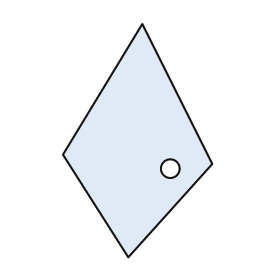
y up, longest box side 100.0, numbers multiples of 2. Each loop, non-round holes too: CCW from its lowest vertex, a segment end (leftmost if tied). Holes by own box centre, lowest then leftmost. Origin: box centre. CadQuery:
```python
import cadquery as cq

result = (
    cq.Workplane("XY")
    .moveTo(-4.0, -50.0)
    .lineTo(32.0, -10.0)
    .lineTo(2.0, 50.0)
    .lineTo(-32.0, -6.0)
    .close()
    .moveTo(14.0, -12.0)
    .circle(4.0)
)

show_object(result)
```